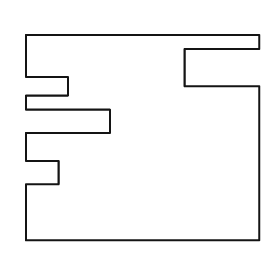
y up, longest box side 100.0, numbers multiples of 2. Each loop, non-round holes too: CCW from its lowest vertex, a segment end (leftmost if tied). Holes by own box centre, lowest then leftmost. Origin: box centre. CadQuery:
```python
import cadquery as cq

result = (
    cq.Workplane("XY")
    .moveTo(-50.0, -44.0)
    .lineTo(50.0, -44.0)
    .lineTo(50.0, 22.0)
    .lineTo(18.0, 22.0)
    .lineTo(18.0, 38.0)
    .lineTo(50.0, 38.0)
    .lineTo(50.0, 44.0)
    .lineTo(-50.0, 44.0)
    .lineTo(-50.0, 26.0)
    .lineTo(-32.0, 26.0)
    .lineTo(-32.0, 18.0)
    .lineTo(-50.0, 18.0)
    .lineTo(-50.0, 12.0)
    .lineTo(-14.0, 12.0)
    .lineTo(-14.0, 2.0)
    .lineTo(-50.0, 2.0)
    .lineTo(-50.0, -10.0)
    .lineTo(-36.0, -10.0)
    .lineTo(-36.0, -20.0)
    .lineTo(-50.0, -20.0)
    .close()
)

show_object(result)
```